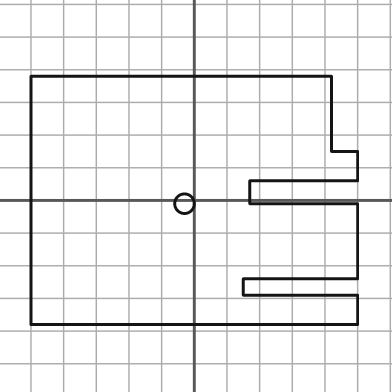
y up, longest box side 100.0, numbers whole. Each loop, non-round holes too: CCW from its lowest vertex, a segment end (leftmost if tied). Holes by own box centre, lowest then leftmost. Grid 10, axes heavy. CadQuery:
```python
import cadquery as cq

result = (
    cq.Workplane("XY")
    .moveTo(-50.0, -38.0)
    .lineTo(50.0, -38.0)
    .lineTo(50.0, -29.0)
    .lineTo(15.0, -29.0)
    .lineTo(15.0, -24.0)
    .lineTo(50.0, -24.0)
    .lineTo(50.0, -1.0)
    .lineTo(17.0, -1.0)
    .lineTo(17.0, 6.0)
    .lineTo(50.0, 6.0)
    .lineTo(50.0, 15.0)
    .lineTo(42.0, 15.0)
    .lineTo(42.0, 38.0)
    .lineTo(-50.0, 38.0)
    .close()
    .moveTo(-3.0, -1.0)
    .circle(3.0)
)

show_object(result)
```